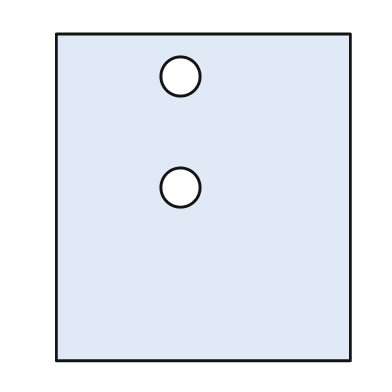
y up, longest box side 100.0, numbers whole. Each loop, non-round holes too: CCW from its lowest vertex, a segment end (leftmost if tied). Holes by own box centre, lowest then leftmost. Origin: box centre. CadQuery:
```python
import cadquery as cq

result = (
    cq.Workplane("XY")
    .moveTo(-45.0, -50.0)
    .lineTo(45.0, -50.0)
    .lineTo(45.0, 50.0)
    .lineTo(-45.0, 50.0)
    .close()
    .moveTo(-7.0, 3.0)
    .circle(6.0)
    .moveTo(-7.0, 37.0)
    .circle(6.0)
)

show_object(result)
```